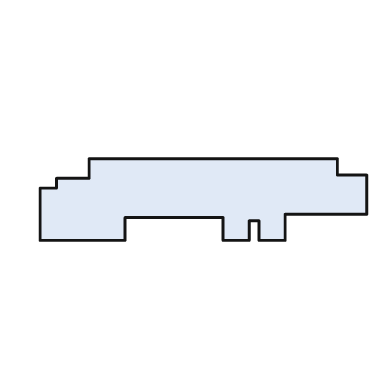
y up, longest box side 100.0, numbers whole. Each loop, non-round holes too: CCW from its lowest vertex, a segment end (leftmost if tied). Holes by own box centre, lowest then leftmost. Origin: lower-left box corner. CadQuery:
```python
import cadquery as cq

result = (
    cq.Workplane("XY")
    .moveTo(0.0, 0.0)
    .lineTo(26.0, 0.0)
    .lineTo(26.0, 7.0)
    .lineTo(56.0, 7.0)
    .lineTo(56.0, 0.0)
    .lineTo(64.0, 0.0)
    .lineTo(64.0, 6.0)
    .lineTo(67.0, 6.0)
    .lineTo(67.0, 0.0)
    .lineTo(75.0, 0.0)
    .lineTo(75.0, 8.0)
    .lineTo(100.0, 8.0)
    .lineTo(100.0, 20.0)
    .lineTo(91.0, 20.0)
    .lineTo(91.0, 25.0)
    .lineTo(15.0, 25.0)
    .lineTo(15.0, 19.0)
    .lineTo(5.0, 19.0)
    .lineTo(5.0, 16.0)
    .lineTo(0.0, 16.0)
    .close()
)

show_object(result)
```